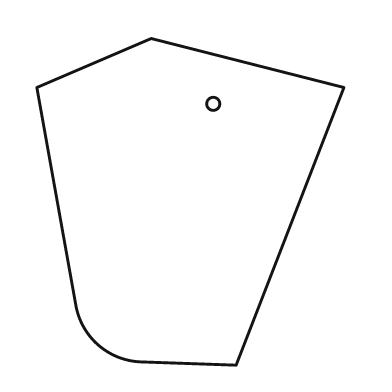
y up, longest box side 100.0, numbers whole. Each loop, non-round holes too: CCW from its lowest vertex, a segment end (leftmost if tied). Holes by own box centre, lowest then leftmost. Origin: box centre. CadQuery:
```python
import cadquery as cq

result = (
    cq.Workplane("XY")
    .moveTo(14.0, -50.0)
    .lineTo(47.0, 35.0)
    .lineTo(-12.0, 50.0)
    .lineTo(-47.0, 35.0)
    .lineTo(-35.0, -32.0)
    .threePointArc((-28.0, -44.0), (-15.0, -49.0))
    .close()
    .moveTo(7.0, 30.0)
    .circle(2.0)
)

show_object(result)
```